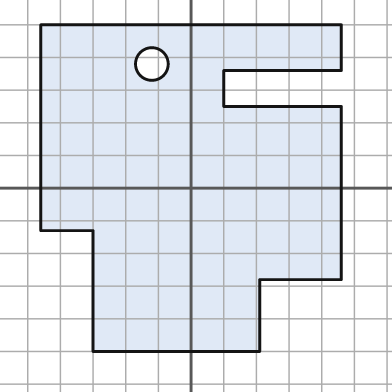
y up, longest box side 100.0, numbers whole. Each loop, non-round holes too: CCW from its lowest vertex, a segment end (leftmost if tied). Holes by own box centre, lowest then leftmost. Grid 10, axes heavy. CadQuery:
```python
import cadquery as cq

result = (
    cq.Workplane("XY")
    .moveTo(-30.0, -50.0)
    .lineTo(21.0, -50.0)
    .lineTo(21.0, -28.0)
    .lineTo(46.0, -28.0)
    .lineTo(46.0, 25.0)
    .lineTo(10.0, 25.0)
    .lineTo(10.0, 36.0)
    .lineTo(46.0, 36.0)
    .lineTo(46.0, 50.0)
    .lineTo(-46.0, 50.0)
    .lineTo(-46.0, -13.0)
    .lineTo(-30.0, -13.0)
    .close()
    .moveTo(-12.0, 38.0)
    .circle(5.0)
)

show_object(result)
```